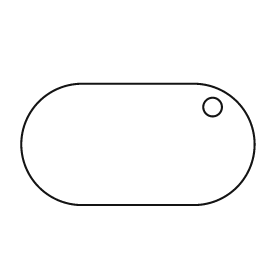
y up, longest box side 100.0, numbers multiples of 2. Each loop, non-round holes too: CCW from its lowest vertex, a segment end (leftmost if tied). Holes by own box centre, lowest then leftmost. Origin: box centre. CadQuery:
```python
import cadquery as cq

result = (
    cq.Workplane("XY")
    .moveTo(-24.0, -26.0)
    .lineTo(24.0, -26.0)
    .threePointArc((50.0, 0.0), (24.0, 26.0))
    .lineTo(-24.0, 26.0)
    .threePointArc((-50.0, 0.0), (-24.0, -26.0))
    .close()
    .moveTo(32.0, 16.0)
    .circle(4.0)
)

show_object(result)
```